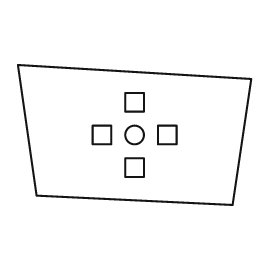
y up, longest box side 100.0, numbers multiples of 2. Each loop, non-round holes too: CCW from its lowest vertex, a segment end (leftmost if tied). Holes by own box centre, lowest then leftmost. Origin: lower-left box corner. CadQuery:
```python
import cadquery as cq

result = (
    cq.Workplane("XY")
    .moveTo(92.0, 0.0)
    .lineTo(100.0, 54.0)
    .lineTo(0.0, 60.0)
    .lineTo(8.0, 4.0)
    .close()
    .moveTo(46.0, 12.0)
    .lineTo(54.0, 12.0)
    .lineTo(54.0, 20.0)
    .lineTo(46.0, 20.0)
    .close()
    .moveTo(32.0, 26.0)
    .lineTo(40.0, 26.0)
    .lineTo(40.0, 34.0)
    .lineTo(32.0, 34.0)
    .close()
    .moveTo(50.0, 30.0)
    .circle(4.0)
    .moveTo(60.0, 26.0)
    .lineTo(68.0, 26.0)
    .lineTo(68.0, 34.0)
    .lineTo(60.0, 34.0)
    .close()
    .moveTo(46.0, 40.0)
    .lineTo(54.0, 40.0)
    .lineTo(54.0, 48.0)
    .lineTo(46.0, 48.0)
    .close()
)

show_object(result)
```